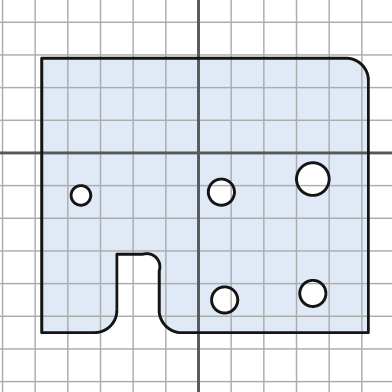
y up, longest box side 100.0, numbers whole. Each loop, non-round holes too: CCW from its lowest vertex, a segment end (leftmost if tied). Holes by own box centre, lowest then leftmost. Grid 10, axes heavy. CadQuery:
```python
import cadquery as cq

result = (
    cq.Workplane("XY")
    .moveTo(-48.0, -55.0)
    .lineTo(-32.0, -55.0)
    .threePointArc((-27.0, -53.0), (-25.0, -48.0))
    .lineTo(-25.0, -31.0)
    .lineTo(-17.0, -31.0)
    .threePointArc((-13.0, -32.0), (-12.0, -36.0))
    .lineTo(-12.0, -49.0)
    .threePointArc((-10.0, -53.0), (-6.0, -55.0))
    .lineTo(52.0, -55.0)
    .lineTo(52.0, 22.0)
    .threePointArc((50.0, 27.0), (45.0, 29.0))
    .lineTo(-48.0, 29.0)
    .close()
    .moveTo(8.0, -45.0)
    .circle(4.0)
    .moveTo(35.0, -43.0)
    .circle(4.0)
    .moveTo(-36.0, -13.0)
    .circle(3.0)
    .moveTo(7.0, -12.0)
    .circle(4.0)
    .moveTo(35.0, -8.0)
    .circle(5.0)
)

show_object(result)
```